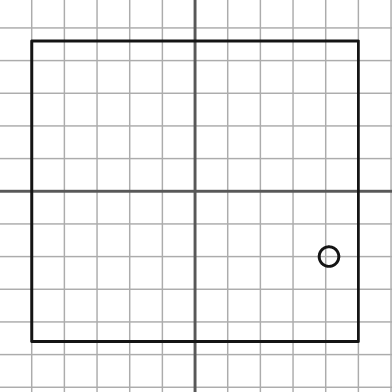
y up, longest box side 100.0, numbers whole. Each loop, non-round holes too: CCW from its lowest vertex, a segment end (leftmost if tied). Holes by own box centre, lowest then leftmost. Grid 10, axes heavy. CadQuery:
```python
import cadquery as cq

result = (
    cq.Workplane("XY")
    .moveTo(-50.0, -46.0)
    .lineTo(50.0, -46.0)
    .lineTo(50.0, 46.0)
    .lineTo(-50.0, 46.0)
    .close()
    .moveTo(41.0, -20.0)
    .circle(3.0)
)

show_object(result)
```